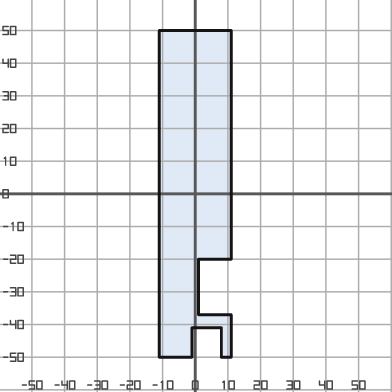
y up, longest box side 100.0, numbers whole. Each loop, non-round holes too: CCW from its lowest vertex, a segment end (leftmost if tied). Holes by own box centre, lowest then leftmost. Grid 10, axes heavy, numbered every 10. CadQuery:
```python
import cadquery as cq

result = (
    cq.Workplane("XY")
    .moveTo(-11.0, -50.0)
    .lineTo(-1.0, -50.0)
    .lineTo(-1.0, -41.0)
    .lineTo(8.0, -41.0)
    .lineTo(8.0, -50.0)
    .lineTo(11.0, -50.0)
    .lineTo(11.0, -37.0)
    .lineTo(1.0, -37.0)
    .lineTo(1.0, -20.0)
    .lineTo(11.0, -20.0)
    .lineTo(11.0, 50.0)
    .lineTo(-11.0, 50.0)
    .close()
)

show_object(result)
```